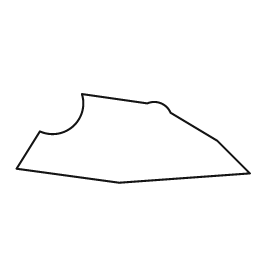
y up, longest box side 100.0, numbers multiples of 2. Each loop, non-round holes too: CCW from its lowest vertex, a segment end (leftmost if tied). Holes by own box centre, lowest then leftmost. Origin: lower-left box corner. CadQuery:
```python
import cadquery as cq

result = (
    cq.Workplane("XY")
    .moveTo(44.0, 0.0)
    .lineTo(100.0, 4.0)
    .lineTo(86.0, 18.0)
    .lineTo(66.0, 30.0)
    .threePointArc((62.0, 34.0), (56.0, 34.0))
    .lineTo(28.0, 38.0)
    .threePointArc((24.0, 24.0), (10.0, 22.0))
    .lineTo(0.0, 6.0)
    .close()
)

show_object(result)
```